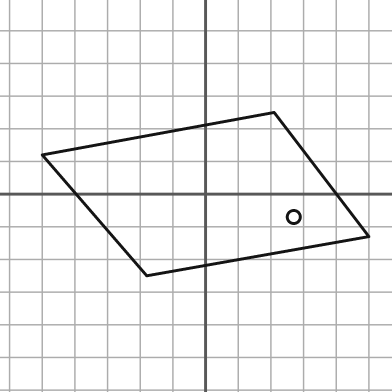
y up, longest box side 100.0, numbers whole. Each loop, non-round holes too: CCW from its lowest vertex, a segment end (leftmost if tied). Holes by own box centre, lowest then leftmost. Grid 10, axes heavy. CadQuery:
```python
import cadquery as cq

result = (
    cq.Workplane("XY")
    .moveTo(-18.0, -25.0)
    .lineTo(50.0, -13.0)
    .lineTo(21.0, 25.0)
    .lineTo(-50.0, 12.0)
    .close()
    .moveTo(27.0, -7.0)
    .circle(2.0)
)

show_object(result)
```